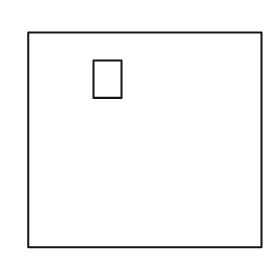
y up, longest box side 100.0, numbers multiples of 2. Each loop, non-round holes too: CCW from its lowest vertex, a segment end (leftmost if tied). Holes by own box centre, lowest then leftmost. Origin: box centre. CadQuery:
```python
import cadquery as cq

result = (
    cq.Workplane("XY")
    .moveTo(-50.0, -46.0)
    .lineTo(50.0, -46.0)
    .lineTo(50.0, 46.0)
    .lineTo(-50.0, 46.0)
    .close()
    .moveTo(-22.0, 18.0)
    .lineTo(-10.0, 18.0)
    .lineTo(-10.0, 34.0)
    .lineTo(-22.0, 34.0)
    .close()
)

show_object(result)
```